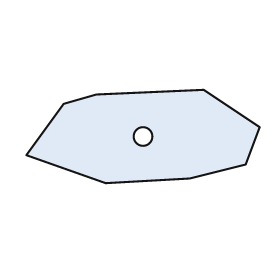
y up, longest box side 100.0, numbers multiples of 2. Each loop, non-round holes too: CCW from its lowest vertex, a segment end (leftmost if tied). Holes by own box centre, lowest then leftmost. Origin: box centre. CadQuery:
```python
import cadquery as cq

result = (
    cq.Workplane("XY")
    .moveTo(-16.0, -20.0)
    .lineTo(20.0, -18.0)
    .lineTo(44.0, -12.0)
    .lineTo(50.0, 4.0)
    .lineTo(26.0, 20.0)
    .lineTo(-20.0, 18.0)
    .lineTo(-34.0, 14.0)
    .lineTo(-50.0, -8.0)
    .close()
    .moveTo(0.0, 0.0)
    .circle(4.0)
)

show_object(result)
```